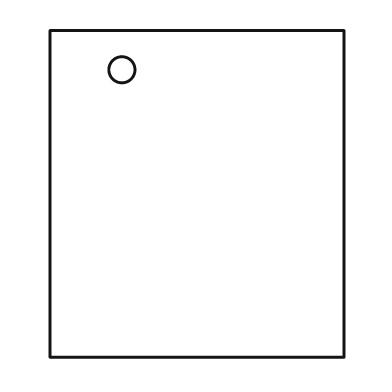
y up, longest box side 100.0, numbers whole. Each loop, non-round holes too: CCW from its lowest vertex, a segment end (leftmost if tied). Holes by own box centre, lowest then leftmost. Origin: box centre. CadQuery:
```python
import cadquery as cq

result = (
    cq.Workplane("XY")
    .moveTo(-45.0, -50.0)
    .lineTo(45.0, -50.0)
    .lineTo(45.0, 50.0)
    .lineTo(-45.0, 50.0)
    .close()
    .moveTo(-23.0, 38.0)
    .circle(4.0)
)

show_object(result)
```